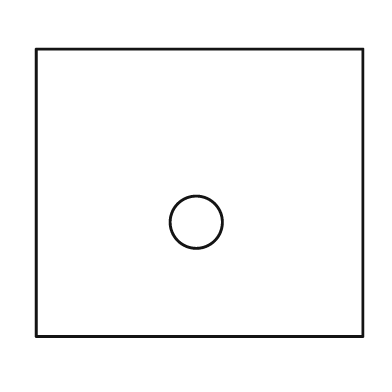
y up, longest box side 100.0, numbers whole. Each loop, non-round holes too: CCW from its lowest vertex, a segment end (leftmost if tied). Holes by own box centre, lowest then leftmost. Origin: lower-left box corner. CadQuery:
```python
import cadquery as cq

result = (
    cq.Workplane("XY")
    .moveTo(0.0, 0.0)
    .lineTo(100.0, 0.0)
    .lineTo(100.0, 88.0)
    .lineTo(0.0, 88.0)
    .close()
    .moveTo(49.0, 35.0)
    .circle(8.0)
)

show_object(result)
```